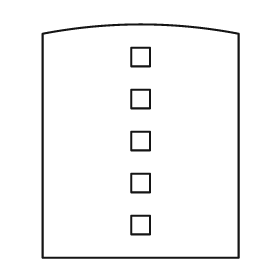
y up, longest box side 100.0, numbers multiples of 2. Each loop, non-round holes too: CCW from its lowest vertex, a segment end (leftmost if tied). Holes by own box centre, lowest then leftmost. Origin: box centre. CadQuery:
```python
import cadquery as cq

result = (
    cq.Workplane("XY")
    .moveTo(-42.0, -50.0)
    .lineTo(42.0, -50.0)
    .lineTo(42.0, 46.0)
    .threePointArc((0.0, 50.0), (-42.0, 46.0))
    .close()
    .moveTo(-4.0, -40.0)
    .lineTo(4.0, -40.0)
    .lineTo(4.0, -32.0)
    .lineTo(-4.0, -32.0)
    .close()
    .moveTo(-4.0, -22.0)
    .lineTo(4.0, -22.0)
    .lineTo(4.0, -14.0)
    .lineTo(-4.0, -14.0)
    .close()
    .moveTo(-4.0, -4.0)
    .lineTo(4.0, -4.0)
    .lineTo(4.0, 4.0)
    .lineTo(-4.0, 4.0)
    .close()
    .moveTo(-4.0, 14.0)
    .lineTo(4.0, 14.0)
    .lineTo(4.0, 22.0)
    .lineTo(-4.0, 22.0)
    .close()
    .moveTo(-4.0, 32.0)
    .lineTo(4.0, 32.0)
    .lineTo(4.0, 40.0)
    .lineTo(-4.0, 40.0)
    .close()
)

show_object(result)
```